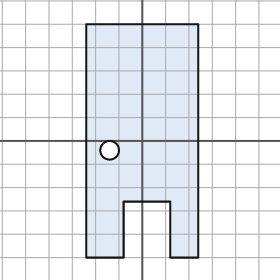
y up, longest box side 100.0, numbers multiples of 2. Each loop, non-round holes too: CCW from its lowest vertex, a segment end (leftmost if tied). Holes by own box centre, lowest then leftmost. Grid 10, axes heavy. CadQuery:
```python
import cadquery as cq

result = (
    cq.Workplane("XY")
    .moveTo(-24.0, -50.0)
    .lineTo(-8.0, -50.0)
    .lineTo(-8.0, -26.0)
    .lineTo(12.0, -26.0)
    .lineTo(12.0, -50.0)
    .lineTo(24.0, -50.0)
    .lineTo(24.0, 50.0)
    .lineTo(-24.0, 50.0)
    .close()
    .moveTo(-14.0, -4.0)
    .circle(4.0)
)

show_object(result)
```